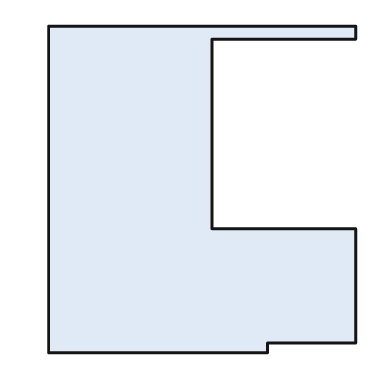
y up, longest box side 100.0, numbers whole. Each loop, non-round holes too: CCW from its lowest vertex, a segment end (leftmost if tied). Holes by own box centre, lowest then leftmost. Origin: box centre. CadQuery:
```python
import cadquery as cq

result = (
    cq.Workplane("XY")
    .moveTo(-47.0, -50.0)
    .lineTo(20.0, -50.0)
    .lineTo(20.0, -47.0)
    .lineTo(47.0, -47.0)
    .lineTo(47.0, -12.0)
    .lineTo(3.0, -12.0)
    .lineTo(3.0, 46.0)
    .lineTo(47.0, 46.0)
    .lineTo(47.0, 50.0)
    .lineTo(-47.0, 50.0)
    .close()
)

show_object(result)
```